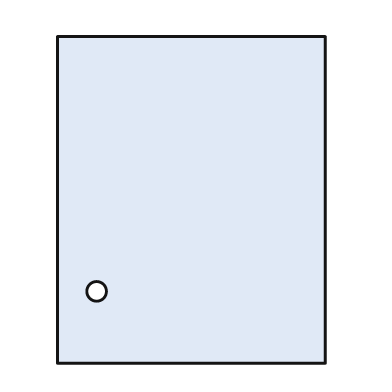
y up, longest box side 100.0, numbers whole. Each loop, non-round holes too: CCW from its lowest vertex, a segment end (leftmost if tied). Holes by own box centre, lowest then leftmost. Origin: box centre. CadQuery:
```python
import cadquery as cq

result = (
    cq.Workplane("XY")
    .moveTo(-41.0, -50.0)
    .lineTo(41.0, -50.0)
    .lineTo(41.0, 50.0)
    .lineTo(-41.0, 50.0)
    .close()
    .moveTo(-29.0, -28.0)
    .circle(3.0)
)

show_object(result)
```